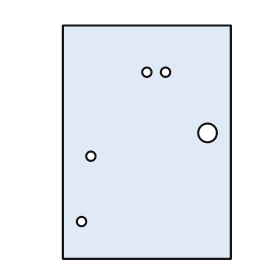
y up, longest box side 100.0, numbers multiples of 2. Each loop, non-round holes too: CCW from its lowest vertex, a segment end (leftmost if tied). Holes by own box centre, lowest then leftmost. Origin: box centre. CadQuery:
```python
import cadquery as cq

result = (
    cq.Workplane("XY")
    .moveTo(-36.0, -50.0)
    .lineTo(36.0, -50.0)
    .lineTo(36.0, 50.0)
    .lineTo(-36.0, 50.0)
    .close()
    .moveTo(-28.0, -34.0)
    .circle(2.0)
    .moveTo(-24.0, -6.0)
    .circle(2.0)
    .moveTo(26.0, 4.0)
    .circle(4.0)
    .moveTo(0.0, 30.0)
    .circle(2.0)
    .moveTo(8.0, 30.0)
    .circle(2.0)
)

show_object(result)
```